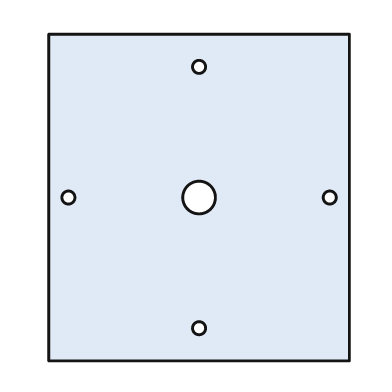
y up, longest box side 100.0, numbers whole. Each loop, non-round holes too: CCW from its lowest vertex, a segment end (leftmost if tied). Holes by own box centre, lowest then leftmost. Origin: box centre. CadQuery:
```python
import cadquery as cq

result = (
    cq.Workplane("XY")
    .moveTo(-46.0, -50.0)
    .lineTo(46.0, -50.0)
    .lineTo(46.0, 50.0)
    .lineTo(-46.0, 50.0)
    .close()
    .moveTo(0.0, -40.0)
    .circle(2.0)
    .moveTo(-40.0, 0.0)
    .circle(2.0)
    .moveTo(0.0, 0.0)
    .circle(5.0)
    .moveTo(40.0, 0.0)
    .circle(2.0)
    .moveTo(0.0, 40.0)
    .circle(2.0)
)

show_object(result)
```